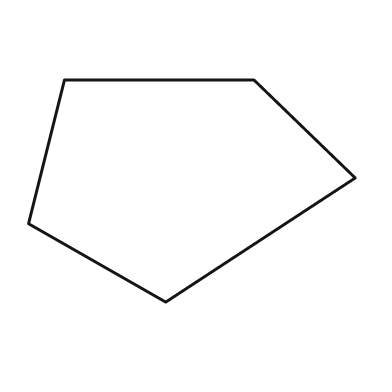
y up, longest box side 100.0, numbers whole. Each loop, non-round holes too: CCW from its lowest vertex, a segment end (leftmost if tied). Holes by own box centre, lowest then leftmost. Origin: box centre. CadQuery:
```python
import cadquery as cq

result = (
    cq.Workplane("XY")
    .moveTo(-8.0, -34.0)
    .lineTo(50.0, 4.0)
    .lineTo(19.0, 34.0)
    .lineTo(-39.0, 34.0)
    .lineTo(-50.0, -10.0)
    .close()
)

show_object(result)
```